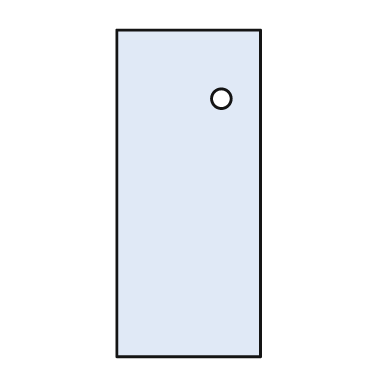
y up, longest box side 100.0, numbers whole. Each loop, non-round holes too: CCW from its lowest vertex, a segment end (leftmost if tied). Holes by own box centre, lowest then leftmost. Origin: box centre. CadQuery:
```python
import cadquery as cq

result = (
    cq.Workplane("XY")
    .moveTo(-22.0, -50.0)
    .lineTo(22.0, -50.0)
    .lineTo(22.0, 50.0)
    .lineTo(-22.0, 50.0)
    .close()
    .moveTo(10.0, 29.0)
    .circle(3.0)
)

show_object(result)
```